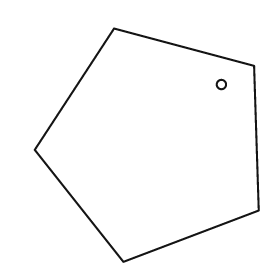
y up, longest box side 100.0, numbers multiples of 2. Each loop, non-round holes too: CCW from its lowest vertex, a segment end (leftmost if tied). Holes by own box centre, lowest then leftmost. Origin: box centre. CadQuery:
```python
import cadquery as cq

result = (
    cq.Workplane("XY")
    .moveTo(-10.0, -50.0)
    .lineTo(48.0, -28.0)
    .lineTo(46.0, 34.0)
    .lineTo(-14.0, 50.0)
    .lineTo(-48.0, -2.0)
    .close()
    .moveTo(32.0, 26.0)
    .circle(2.0)
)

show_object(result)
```